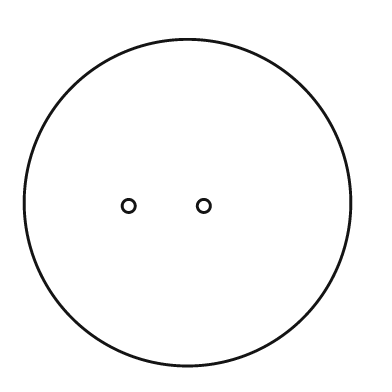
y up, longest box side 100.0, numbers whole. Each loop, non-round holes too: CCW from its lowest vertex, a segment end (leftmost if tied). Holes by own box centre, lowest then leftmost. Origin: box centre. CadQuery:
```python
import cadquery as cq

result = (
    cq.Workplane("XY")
    .moveTo(0.0, 0.0)
    .circle(50.0)
    .moveTo(-18.0, -1.0)
    .circle(2.0)
    .moveTo(5.0, -1.0)
    .circle(2.0)
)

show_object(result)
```